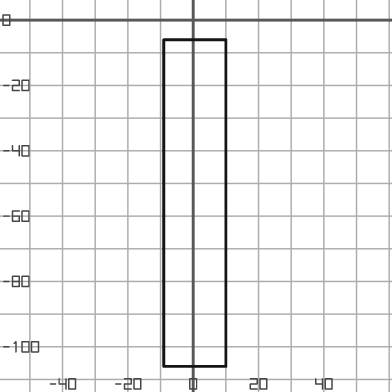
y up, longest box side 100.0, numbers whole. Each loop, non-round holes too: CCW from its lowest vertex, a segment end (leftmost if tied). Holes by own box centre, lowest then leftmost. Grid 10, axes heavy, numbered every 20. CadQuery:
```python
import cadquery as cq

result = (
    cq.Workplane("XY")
    .moveTo(-9.0, -106.0)
    .lineTo(10.0, -106.0)
    .lineTo(10.0, -6.0)
    .lineTo(-9.0, -6.0)
    .close()
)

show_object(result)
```